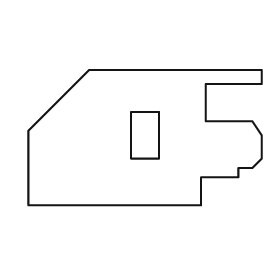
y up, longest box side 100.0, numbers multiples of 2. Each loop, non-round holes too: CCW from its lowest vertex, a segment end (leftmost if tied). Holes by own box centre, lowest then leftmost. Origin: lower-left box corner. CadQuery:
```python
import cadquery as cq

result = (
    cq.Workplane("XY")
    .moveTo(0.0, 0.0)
    .lineTo(74.0, 0.0)
    .lineTo(74.0, 12.0)
    .lineTo(90.0, 12.0)
    .lineTo(90.0, 16.0)
    .lineTo(96.0, 16.0)
    .lineTo(100.0, 20.0)
    .lineTo(100.0, 30.0)
    .lineTo(96.0, 36.0)
    .lineTo(76.0, 36.0)
    .lineTo(76.0, 52.0)
    .lineTo(100.0, 52.0)
    .lineTo(100.0, 58.0)
    .lineTo(26.0, 58.0)
    .lineTo(0.0, 32.0)
    .close()
    .moveTo(44.0, 20.0)
    .lineTo(56.0, 20.0)
    .lineTo(56.0, 40.0)
    .lineTo(44.0, 40.0)
    .close()
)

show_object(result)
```